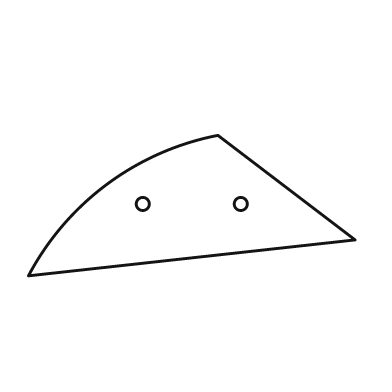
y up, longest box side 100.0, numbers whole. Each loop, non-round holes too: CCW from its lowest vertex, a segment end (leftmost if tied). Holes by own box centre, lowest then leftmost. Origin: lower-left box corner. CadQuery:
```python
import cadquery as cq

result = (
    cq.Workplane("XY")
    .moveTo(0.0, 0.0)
    .lineTo(100.0, 11.0)
    .lineTo(58.0, 43.0)
    .threePointArc((24.0, 28.0), (0.0, 0.0))
    .close()
    .moveTo(35.0, 22.0)
    .circle(2.0)
    .moveTo(65.0, 22.0)
    .circle(2.0)
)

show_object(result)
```